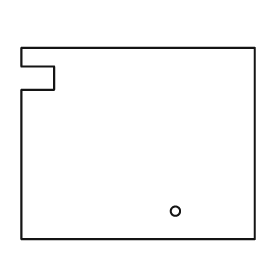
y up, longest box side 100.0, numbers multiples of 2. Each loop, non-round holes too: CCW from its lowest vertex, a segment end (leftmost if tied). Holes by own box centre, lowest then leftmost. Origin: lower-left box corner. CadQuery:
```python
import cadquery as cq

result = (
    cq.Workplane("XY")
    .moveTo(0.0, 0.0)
    .lineTo(100.0, 0.0)
    .lineTo(100.0, 82.0)
    .lineTo(0.0, 82.0)
    .lineTo(0.0, 74.0)
    .lineTo(14.0, 74.0)
    .lineTo(14.0, 64.0)
    .lineTo(0.0, 64.0)
    .close()
    .moveTo(66.0, 12.0)
    .circle(2.0)
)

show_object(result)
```